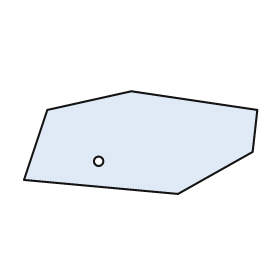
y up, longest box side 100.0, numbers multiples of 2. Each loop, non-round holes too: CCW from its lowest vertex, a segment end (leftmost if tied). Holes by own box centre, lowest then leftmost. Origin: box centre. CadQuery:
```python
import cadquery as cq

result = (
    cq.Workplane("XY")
    .moveTo(16.0, -22.0)
    .lineTo(48.0, -4.0)
    .lineTo(50.0, 14.0)
    .lineTo(-4.0, 22.0)
    .lineTo(-40.0, 14.0)
    .lineTo(-50.0, -16.0)
    .close()
    .moveTo(-18.0, -8.0)
    .circle(2.0)
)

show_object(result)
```